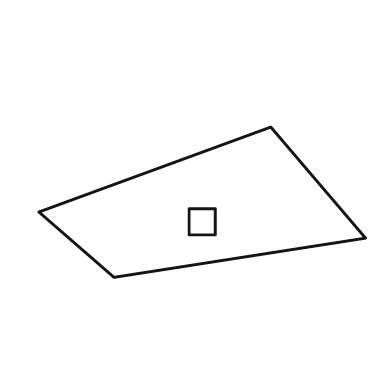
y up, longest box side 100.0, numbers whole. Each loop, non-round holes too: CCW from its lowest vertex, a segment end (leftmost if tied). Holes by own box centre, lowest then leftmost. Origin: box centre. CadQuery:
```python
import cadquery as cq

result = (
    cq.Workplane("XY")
    .moveTo(-27.0, -23.0)
    .lineTo(50.0, -11.0)
    .lineTo(21.0, 23.0)
    .lineTo(-50.0, -3.0)
    .close()
    .moveTo(-4.0, -10.0)
    .lineTo(4.0, -10.0)
    .lineTo(4.0, -2.0)
    .lineTo(-4.0, -2.0)
    .close()
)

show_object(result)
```